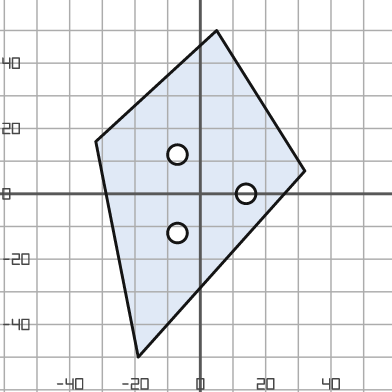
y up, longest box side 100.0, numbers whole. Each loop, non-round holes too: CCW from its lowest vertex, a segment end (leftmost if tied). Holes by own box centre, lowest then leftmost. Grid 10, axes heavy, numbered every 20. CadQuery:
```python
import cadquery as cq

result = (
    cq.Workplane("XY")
    .moveTo(-19.0, -50.0)
    .lineTo(32.0, 7.0)
    .lineTo(5.0, 50.0)
    .lineTo(-32.0, 16.0)
    .close()
    .moveTo(-7.0, -12.0)
    .circle(3.0)
    .moveTo(14.0, 0.0)
    .circle(3.0)
    .moveTo(-7.0, 12.0)
    .circle(3.0)
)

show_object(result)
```